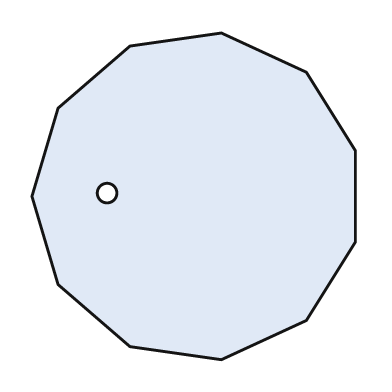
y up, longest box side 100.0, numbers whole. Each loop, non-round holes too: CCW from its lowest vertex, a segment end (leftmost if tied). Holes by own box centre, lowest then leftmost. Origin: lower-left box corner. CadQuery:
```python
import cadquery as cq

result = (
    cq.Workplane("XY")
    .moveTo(58.0, 0.0)
    .lineTo(84.0, 12.0)
    .lineTo(99.0, 36.0)
    .lineTo(99.0, 64.0)
    .lineTo(84.0, 88.0)
    .lineTo(58.0, 100.0)
    .lineTo(30.0, 96.0)
    .lineTo(8.0, 77.0)
    .lineTo(0.0, 50.0)
    .lineTo(8.0, 23.0)
    .lineTo(30.0, 4.0)
    .close()
    .moveTo(23.0, 51.0)
    .circle(3.0)
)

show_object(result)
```